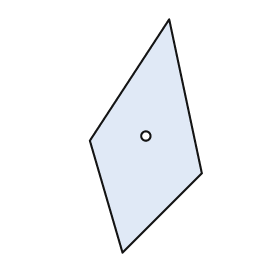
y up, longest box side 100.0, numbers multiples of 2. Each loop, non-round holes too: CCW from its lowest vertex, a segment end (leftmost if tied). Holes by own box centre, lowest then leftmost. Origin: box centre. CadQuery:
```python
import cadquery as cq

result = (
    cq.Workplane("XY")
    .moveTo(-10.0, -50.0)
    .lineTo(24.0, -16.0)
    .lineTo(10.0, 50.0)
    .lineTo(-24.0, -2.0)
    .close()
    .moveTo(0.0, 0.0)
    .circle(2.0)
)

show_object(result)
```